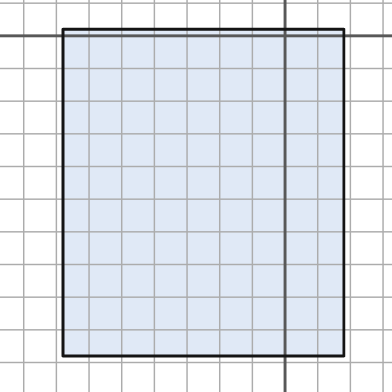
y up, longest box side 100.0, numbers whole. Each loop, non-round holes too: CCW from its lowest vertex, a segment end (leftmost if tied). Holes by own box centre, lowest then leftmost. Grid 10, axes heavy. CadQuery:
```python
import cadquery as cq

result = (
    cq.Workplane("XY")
    .moveTo(-68.0, -98.0)
    .lineTo(18.0, -98.0)
    .lineTo(18.0, 2.0)
    .lineTo(-68.0, 2.0)
    .close()
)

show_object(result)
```